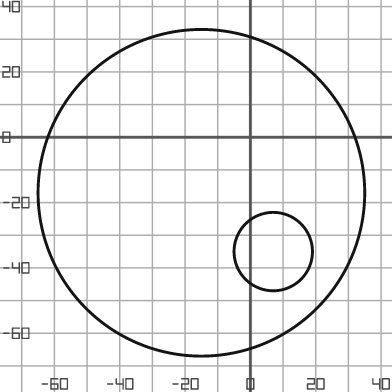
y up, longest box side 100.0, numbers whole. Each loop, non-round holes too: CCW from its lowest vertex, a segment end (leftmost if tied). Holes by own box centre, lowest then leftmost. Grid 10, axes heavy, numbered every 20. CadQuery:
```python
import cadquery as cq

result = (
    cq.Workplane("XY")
    .moveTo(-15.0, -17.0)
    .circle(50.0)
    .moveTo(7.0, -35.0)
    .circle(12.0)
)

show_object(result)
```